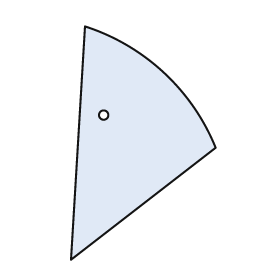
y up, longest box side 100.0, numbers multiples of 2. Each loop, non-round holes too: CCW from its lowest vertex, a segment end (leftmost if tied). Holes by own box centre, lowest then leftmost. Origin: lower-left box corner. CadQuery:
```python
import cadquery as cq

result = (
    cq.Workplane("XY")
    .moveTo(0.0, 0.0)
    .lineTo(62.0, 48.0)
    .threePointArc((40.0, 80.0), (6.0, 100.0))
    .close()
    .moveTo(14.0, 62.0)
    .circle(2.0)
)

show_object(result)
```